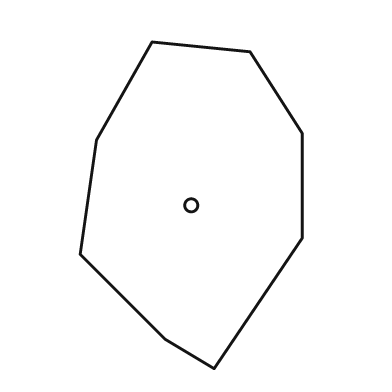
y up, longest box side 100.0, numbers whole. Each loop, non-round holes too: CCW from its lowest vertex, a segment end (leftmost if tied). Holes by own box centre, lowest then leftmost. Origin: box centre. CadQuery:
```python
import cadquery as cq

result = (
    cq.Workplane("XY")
    .moveTo(7.0, -50.0)
    .lineTo(34.0, -10.0)
    .lineTo(34.0, 22.0)
    .lineTo(18.0, 47.0)
    .lineTo(-12.0, 50.0)
    .lineTo(-29.0, 20.0)
    .lineTo(-34.0, -15.0)
    .lineTo(-8.0, -41.0)
    .close()
    .moveTo(0.0, 0.0)
    .circle(2.0)
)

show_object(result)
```